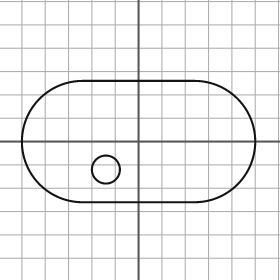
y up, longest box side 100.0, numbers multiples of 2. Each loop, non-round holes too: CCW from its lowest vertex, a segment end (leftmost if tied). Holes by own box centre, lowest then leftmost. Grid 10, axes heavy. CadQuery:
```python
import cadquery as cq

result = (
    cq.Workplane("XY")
    .moveTo(-24.0, -26.0)
    .lineTo(24.0, -26.0)
    .threePointArc((50.0, 0.0), (24.0, 26.0))
    .lineTo(-24.0, 26.0)
    .threePointArc((-50.0, 0.0), (-24.0, -26.0))
    .close()
    .moveTo(-14.0, -12.0)
    .circle(6.0)
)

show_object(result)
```